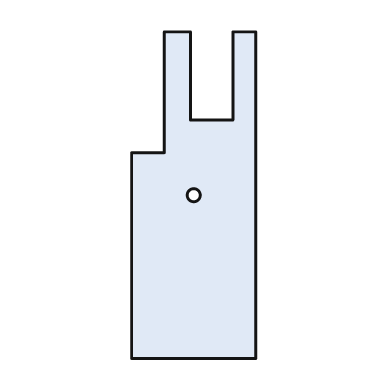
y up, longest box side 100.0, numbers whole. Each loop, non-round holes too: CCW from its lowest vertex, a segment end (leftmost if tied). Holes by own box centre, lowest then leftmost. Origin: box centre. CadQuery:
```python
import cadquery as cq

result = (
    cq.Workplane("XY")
    .moveTo(-19.0, -50.0)
    .lineTo(19.0, -50.0)
    .lineTo(19.0, 50.0)
    .lineTo(12.0, 50.0)
    .lineTo(12.0, 23.0)
    .lineTo(-1.0, 23.0)
    .lineTo(-1.0, 50.0)
    .lineTo(-9.0, 50.0)
    .lineTo(-9.0, 13.0)
    .lineTo(-19.0, 13.0)
    .close()
    .moveTo(0.0, 0.0)
    .circle(2.0)
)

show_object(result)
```